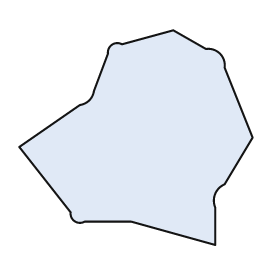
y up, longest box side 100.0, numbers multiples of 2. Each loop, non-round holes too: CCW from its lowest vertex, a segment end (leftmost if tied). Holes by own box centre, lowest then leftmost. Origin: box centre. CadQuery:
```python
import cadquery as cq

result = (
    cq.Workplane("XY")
    .moveTo(34.0, -46.0)
    .lineTo(34.0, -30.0)
    .threePointArc((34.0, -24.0), (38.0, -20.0))
    .lineTo(50.0, 0.0)
    .lineTo(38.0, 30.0)
    .threePointArc((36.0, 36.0), (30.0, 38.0))
    .lineTo(16.0, 46.0)
    .lineTo(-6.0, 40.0)
    .threePointArc((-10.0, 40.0), (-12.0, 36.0))
    .lineTo(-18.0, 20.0)
    .threePointArc((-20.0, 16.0), (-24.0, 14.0))
    .lineTo(-50.0, -4.0)
    .lineTo(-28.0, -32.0)
    .threePointArc((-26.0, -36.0), (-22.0, -36.0))
    .lineTo(-2.0, -36.0)
    .close()
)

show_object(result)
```